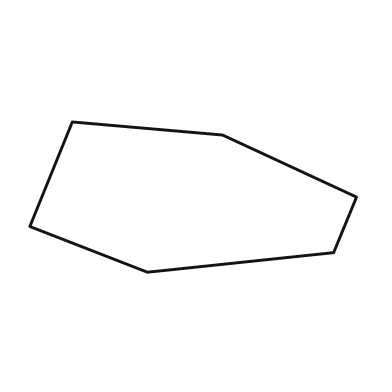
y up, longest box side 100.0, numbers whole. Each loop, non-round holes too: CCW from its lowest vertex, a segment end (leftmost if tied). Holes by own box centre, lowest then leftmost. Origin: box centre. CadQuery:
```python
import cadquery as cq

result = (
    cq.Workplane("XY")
    .moveTo(-14.0, -23.0)
    .lineTo(43.0, -17.0)
    .lineTo(50.0, 0.0)
    .lineTo(9.0, 19.0)
    .lineTo(-37.0, 23.0)
    .lineTo(-50.0, -9.0)
    .close()
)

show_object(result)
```